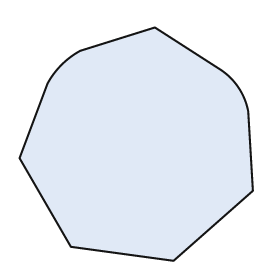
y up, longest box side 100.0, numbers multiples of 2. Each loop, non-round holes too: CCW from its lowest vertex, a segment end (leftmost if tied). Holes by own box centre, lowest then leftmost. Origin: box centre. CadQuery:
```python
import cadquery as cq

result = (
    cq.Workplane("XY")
    .moveTo(16.0, -50.0)
    .lineTo(50.0, -20.0)
    .lineTo(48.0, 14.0)
    .threePointArc((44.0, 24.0), (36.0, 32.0))
    .lineTo(8.0, 50.0)
    .lineTo(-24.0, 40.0)
    .threePointArc((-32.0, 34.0), (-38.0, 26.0))
    .lineTo(-50.0, -6.0)
    .lineTo(-28.0, -44.0)
    .close()
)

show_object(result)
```